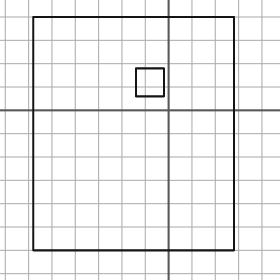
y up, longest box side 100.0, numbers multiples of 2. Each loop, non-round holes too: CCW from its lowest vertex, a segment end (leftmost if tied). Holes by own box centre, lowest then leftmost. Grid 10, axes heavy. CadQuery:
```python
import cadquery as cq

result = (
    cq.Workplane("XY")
    .moveTo(-58.0, -60.0)
    .lineTo(28.0, -60.0)
    .lineTo(28.0, 40.0)
    .lineTo(-58.0, 40.0)
    .close()
    .moveTo(-14.0, 6.0)
    .lineTo(-2.0, 6.0)
    .lineTo(-2.0, 18.0)
    .lineTo(-14.0, 18.0)
    .close()
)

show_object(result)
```